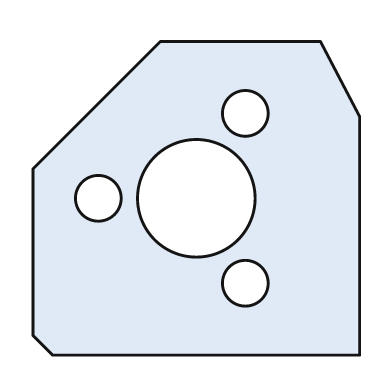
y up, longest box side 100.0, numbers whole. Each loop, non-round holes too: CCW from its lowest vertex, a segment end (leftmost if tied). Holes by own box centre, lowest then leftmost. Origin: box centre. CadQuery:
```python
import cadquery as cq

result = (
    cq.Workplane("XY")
    .moveTo(-44.0, -48.0)
    .lineTo(50.0, -48.0)
    .lineTo(50.0, 25.0)
    .lineTo(38.0, 48.0)
    .lineTo(-11.0, 48.0)
    .lineTo(-50.0, 9.0)
    .lineTo(-50.0, -42.0)
    .close()
    .moveTo(15.0, -26.0)
    .circle(7.0)
    .moveTo(-30.0, 0.0)
    .circle(7.0)
    .moveTo(0.0, 0.0)
    .circle(18.0)
    .moveTo(15.0, 26.0)
    .circle(7.0)
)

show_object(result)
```